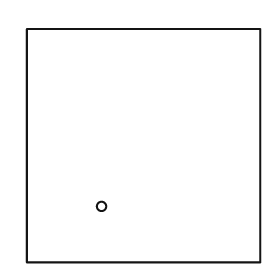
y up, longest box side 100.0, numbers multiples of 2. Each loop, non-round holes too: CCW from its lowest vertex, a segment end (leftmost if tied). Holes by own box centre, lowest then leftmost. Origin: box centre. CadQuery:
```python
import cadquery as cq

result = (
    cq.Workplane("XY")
    .moveTo(-50.0, -50.0)
    .lineTo(50.0, -50.0)
    .lineTo(50.0, 50.0)
    .lineTo(-50.0, 50.0)
    .close()
    .moveTo(-18.0, -26.0)
    .circle(2.0)
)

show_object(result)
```